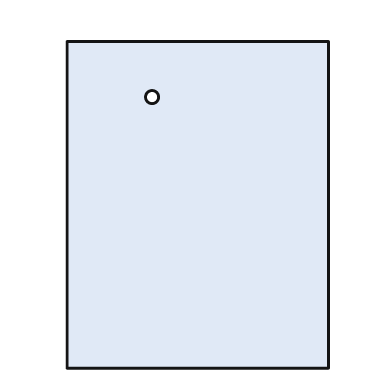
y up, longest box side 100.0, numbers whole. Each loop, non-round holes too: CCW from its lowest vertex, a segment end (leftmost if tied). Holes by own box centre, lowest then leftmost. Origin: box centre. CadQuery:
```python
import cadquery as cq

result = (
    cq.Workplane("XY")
    .moveTo(-40.0, -50.0)
    .lineTo(40.0, -50.0)
    .lineTo(40.0, 50.0)
    .lineTo(-40.0, 50.0)
    .close()
    .moveTo(-14.0, 33.0)
    .circle(2.0)
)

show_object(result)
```